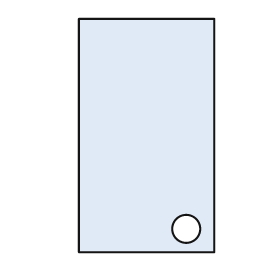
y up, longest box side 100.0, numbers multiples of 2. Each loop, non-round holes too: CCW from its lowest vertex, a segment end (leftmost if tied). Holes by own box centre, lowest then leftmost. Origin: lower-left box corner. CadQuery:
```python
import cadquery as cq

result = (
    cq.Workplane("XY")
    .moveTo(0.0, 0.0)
    .lineTo(58.0, 0.0)
    .lineTo(58.0, 100.0)
    .lineTo(0.0, 100.0)
    .close()
    .moveTo(46.0, 10.0)
    .circle(6.0)
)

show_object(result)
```